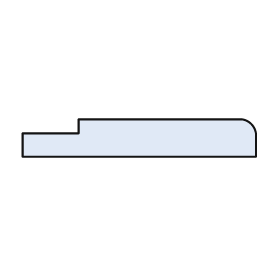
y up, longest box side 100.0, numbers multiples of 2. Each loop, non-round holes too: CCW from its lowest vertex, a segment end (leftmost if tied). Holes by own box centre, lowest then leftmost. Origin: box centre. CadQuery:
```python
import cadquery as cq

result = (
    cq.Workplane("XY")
    .moveTo(-50.0, -8.0)
    .lineTo(50.0, -8.0)
    .lineTo(50.0, 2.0)
    .threePointArc((48.0, 6.0), (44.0, 8.0))
    .lineTo(-26.0, 8.0)
    .lineTo(-26.0, 2.0)
    .lineTo(-50.0, 2.0)
    .close()
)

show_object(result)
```